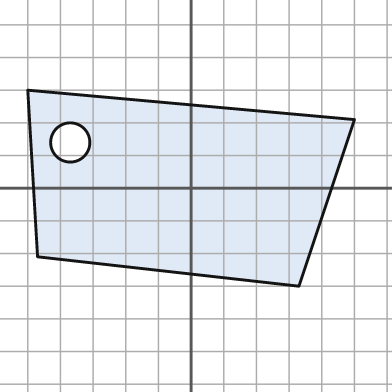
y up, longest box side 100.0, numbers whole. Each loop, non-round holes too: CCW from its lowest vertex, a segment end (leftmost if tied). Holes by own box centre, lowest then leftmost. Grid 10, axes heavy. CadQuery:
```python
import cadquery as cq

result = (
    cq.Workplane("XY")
    .moveTo(33.0, -30.0)
    .lineTo(50.0, 21.0)
    .lineTo(-50.0, 30.0)
    .lineTo(-47.0, -21.0)
    .close()
    .moveTo(-37.0, 14.0)
    .circle(6.0)
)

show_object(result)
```